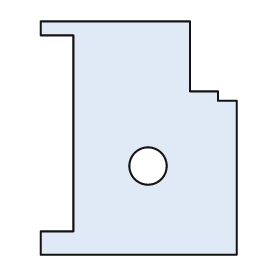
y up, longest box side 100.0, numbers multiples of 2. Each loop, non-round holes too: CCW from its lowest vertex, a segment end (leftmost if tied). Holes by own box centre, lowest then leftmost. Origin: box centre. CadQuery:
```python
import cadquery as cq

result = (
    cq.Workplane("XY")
    .moveTo(-42.0, -50.0)
    .lineTo(42.0, -50.0)
    .lineTo(42.0, 16.0)
    .lineTo(34.0, 16.0)
    .lineTo(34.0, 20.0)
    .lineTo(22.0, 20.0)
    .lineTo(22.0, 50.0)
    .lineTo(-42.0, 50.0)
    .lineTo(-42.0, 44.0)
    .lineTo(-28.0, 44.0)
    .lineTo(-28.0, -40.0)
    .lineTo(-42.0, -40.0)
    .close()
    .moveTo(4.0, -12.0)
    .circle(8.0)
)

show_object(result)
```